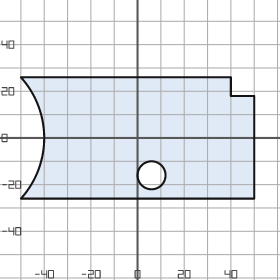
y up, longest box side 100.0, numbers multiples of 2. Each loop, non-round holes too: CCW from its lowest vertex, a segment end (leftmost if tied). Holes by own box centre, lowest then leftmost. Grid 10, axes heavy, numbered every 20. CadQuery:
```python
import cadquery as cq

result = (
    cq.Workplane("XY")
    .moveTo(-50.0, -26.0)
    .lineTo(50.0, -26.0)
    .lineTo(50.0, 18.0)
    .lineTo(40.0, 18.0)
    .lineTo(40.0, 26.0)
    .lineTo(-50.0, 26.0)
    .threePointArc((-40.0, 0.0), (-50.0, -26.0))
    .close()
    .moveTo(6.0, -16.0)
    .circle(6.0)
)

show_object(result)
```